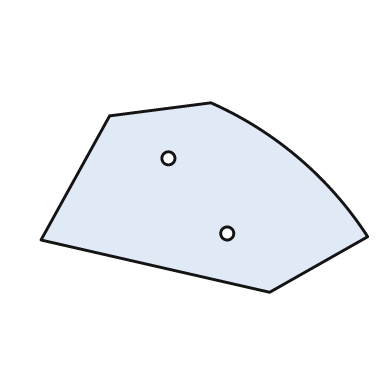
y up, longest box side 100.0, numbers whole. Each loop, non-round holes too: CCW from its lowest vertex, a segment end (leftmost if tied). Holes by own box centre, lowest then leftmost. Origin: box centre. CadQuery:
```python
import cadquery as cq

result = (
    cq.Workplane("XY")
    .moveTo(20.0, -29.0)
    .lineTo(50.0, -12.0)
    .threePointArc((29.0, 12.0), (2.0, 29.0))
    .lineTo(-29.0, 25.0)
    .lineTo(-50.0, -13.0)
    .close()
    .moveTo(7.0, -11.0)
    .circle(2.0)
    .moveTo(-11.0, 12.0)
    .circle(2.0)
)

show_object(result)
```